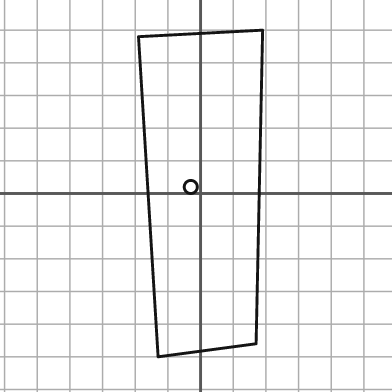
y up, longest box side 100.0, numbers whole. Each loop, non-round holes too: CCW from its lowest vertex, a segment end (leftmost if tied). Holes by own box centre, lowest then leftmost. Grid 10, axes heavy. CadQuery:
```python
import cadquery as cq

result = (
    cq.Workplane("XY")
    .moveTo(-13.0, -50.0)
    .lineTo(17.0, -46.0)
    .lineTo(19.0, 50.0)
    .lineTo(-19.0, 48.0)
    .close()
    .moveTo(-3.0, 2.0)
    .circle(2.0)
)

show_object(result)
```